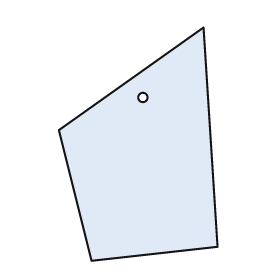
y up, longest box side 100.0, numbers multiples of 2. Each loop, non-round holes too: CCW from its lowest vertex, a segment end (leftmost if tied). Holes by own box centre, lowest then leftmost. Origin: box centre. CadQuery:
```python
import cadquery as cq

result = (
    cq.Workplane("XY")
    .moveTo(-20.0, -50.0)
    .lineTo(34.0, -44.0)
    .lineTo(28.0, 50.0)
    .lineTo(-34.0, 6.0)
    .close()
    .moveTo(2.0, 20.0)
    .circle(2.0)
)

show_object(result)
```